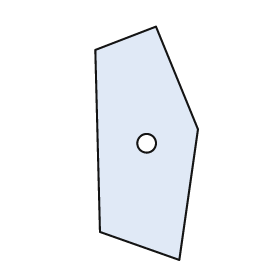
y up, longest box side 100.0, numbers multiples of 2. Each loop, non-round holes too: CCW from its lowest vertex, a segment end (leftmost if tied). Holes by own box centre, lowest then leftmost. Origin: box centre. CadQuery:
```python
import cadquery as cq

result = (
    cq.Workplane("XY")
    .moveTo(14.0, -50.0)
    .lineTo(22.0, 6.0)
    .lineTo(4.0, 50.0)
    .lineTo(-22.0, 40.0)
    .lineTo(-20.0, -38.0)
    .close()
    .moveTo(0.0, 0.0)
    .circle(4.0)
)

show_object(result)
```